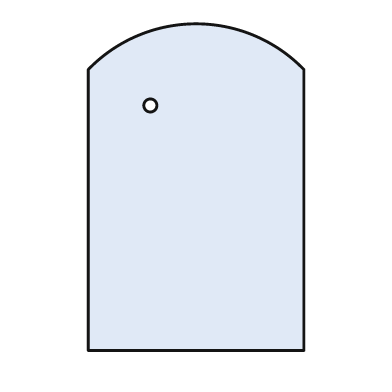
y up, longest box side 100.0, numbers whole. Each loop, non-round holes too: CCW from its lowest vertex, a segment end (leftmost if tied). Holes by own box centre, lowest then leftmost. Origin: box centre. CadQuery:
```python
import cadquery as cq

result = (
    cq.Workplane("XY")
    .moveTo(-33.0, -50.0)
    .lineTo(33.0, -50.0)
    .lineTo(33.0, 36.0)
    .threePointArc((0.0, 50.0), (-33.0, 36.0))
    .close()
    .moveTo(-14.0, 25.0)
    .circle(2.0)
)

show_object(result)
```